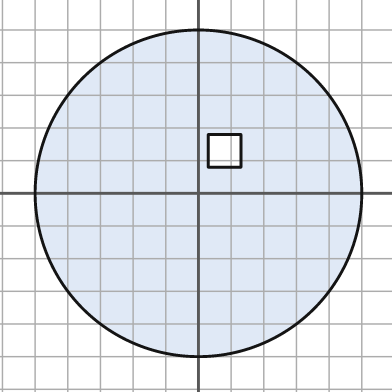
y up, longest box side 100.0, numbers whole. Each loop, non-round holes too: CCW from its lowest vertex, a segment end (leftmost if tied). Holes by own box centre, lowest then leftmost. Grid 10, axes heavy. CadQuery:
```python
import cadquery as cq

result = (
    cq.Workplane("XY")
    .moveTo(0.0, 0.0)
    .circle(50.0)
    .moveTo(3.0, 8.0)
    .lineTo(13.0, 8.0)
    .lineTo(13.0, 18.0)
    .lineTo(3.0, 18.0)
    .close()
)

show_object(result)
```